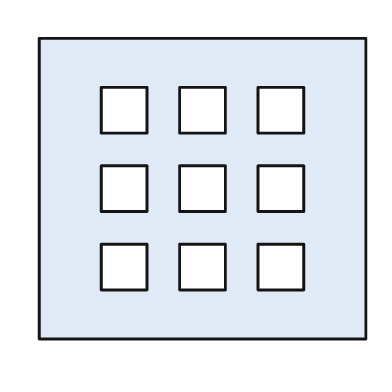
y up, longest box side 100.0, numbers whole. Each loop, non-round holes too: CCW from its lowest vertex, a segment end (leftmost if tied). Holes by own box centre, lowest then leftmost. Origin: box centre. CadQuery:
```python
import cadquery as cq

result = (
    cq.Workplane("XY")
    .moveTo(-50.0, -46.0)
    .lineTo(50.0, -46.0)
    .lineTo(50.0, 46.0)
    .lineTo(-50.0, 46.0)
    .close()
    .moveTo(-31.0, -31.0)
    .lineTo(-17.0, -31.0)
    .lineTo(-17.0, -17.0)
    .lineTo(-31.0, -17.0)
    .close()
    .moveTo(-7.0, -31.0)
    .lineTo(7.0, -31.0)
    .lineTo(7.0, -17.0)
    .lineTo(-7.0, -17.0)
    .close()
    .moveTo(17.0, -31.0)
    .lineTo(31.0, -31.0)
    .lineTo(31.0, -17.0)
    .lineTo(17.0, -17.0)
    .close()
    .moveTo(-31.0, -7.0)
    .lineTo(-17.0, -7.0)
    .lineTo(-17.0, 7.0)
    .lineTo(-31.0, 7.0)
    .close()
    .moveTo(-7.0, -7.0)
    .lineTo(7.0, -7.0)
    .lineTo(7.0, 7.0)
    .lineTo(-7.0, 7.0)
    .close()
    .moveTo(17.0, -7.0)
    .lineTo(31.0, -7.0)
    .lineTo(31.0, 7.0)
    .lineTo(17.0, 7.0)
    .close()
    .moveTo(-31.0, 17.0)
    .lineTo(-17.0, 17.0)
    .lineTo(-17.0, 31.0)
    .lineTo(-31.0, 31.0)
    .close()
    .moveTo(-7.0, 17.0)
    .lineTo(7.0, 17.0)
    .lineTo(7.0, 31.0)
    .lineTo(-7.0, 31.0)
    .close()
    .moveTo(17.0, 17.0)
    .lineTo(31.0, 17.0)
    .lineTo(31.0, 31.0)
    .lineTo(17.0, 31.0)
    .close()
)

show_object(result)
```